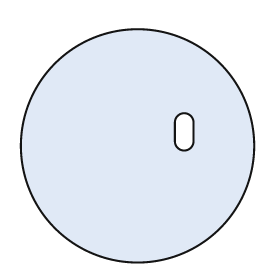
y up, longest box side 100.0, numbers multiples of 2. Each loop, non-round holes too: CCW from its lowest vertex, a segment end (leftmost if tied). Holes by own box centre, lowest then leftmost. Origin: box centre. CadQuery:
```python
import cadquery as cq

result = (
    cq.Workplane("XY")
    .moveTo(0.0, 0.0)
    .circle(50.0)
    .moveTo(16.0, 2.0)
    .threePointArc((20.0, -2.0), (24.0, 2.0))
    .lineTo(24.0, 10.0)
    .threePointArc((20.0, 14.0), (16.0, 10.0))
    .close()
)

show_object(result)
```